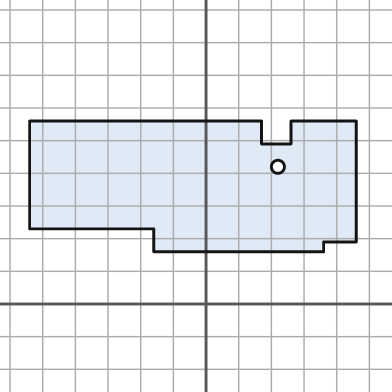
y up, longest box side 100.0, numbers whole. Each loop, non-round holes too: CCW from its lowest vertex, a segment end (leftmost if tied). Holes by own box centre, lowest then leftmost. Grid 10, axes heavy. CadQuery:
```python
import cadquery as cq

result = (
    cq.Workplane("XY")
    .moveTo(-16.0, 16.0)
    .lineTo(36.0, 16.0)
    .lineTo(36.0, 19.0)
    .lineTo(46.0, 19.0)
    .lineTo(46.0, 56.0)
    .lineTo(26.0, 56.0)
    .lineTo(26.0, 49.0)
    .lineTo(17.0, 49.0)
    .lineTo(17.0, 56.0)
    .lineTo(-54.0, 56.0)
    .lineTo(-54.0, 23.0)
    .lineTo(-16.0, 23.0)
    .close()
    .moveTo(22.0, 42.0)
    .circle(2.0)
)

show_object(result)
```